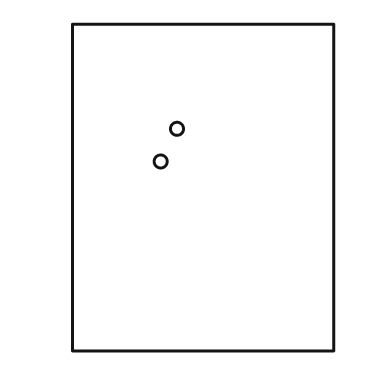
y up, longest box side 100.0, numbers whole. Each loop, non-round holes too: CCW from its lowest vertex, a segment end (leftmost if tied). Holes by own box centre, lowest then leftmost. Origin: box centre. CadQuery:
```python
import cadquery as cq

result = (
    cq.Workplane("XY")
    .moveTo(-40.0, -50.0)
    .lineTo(40.0, -50.0)
    .lineTo(40.0, 50.0)
    .lineTo(-40.0, 50.0)
    .close()
    .moveTo(-13.0, 8.0)
    .circle(2.0)
    .moveTo(-8.0, 18.0)
    .circle(2.0)
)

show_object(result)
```